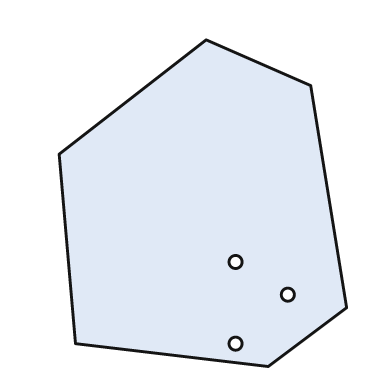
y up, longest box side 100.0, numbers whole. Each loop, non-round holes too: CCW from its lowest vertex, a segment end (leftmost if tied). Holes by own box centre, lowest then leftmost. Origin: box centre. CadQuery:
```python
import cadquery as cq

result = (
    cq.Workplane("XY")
    .moveTo(20.0, -50.0)
    .lineTo(44.0, -32.0)
    .lineTo(33.0, 36.0)
    .lineTo(1.0, 50.0)
    .lineTo(-44.0, 15.0)
    .lineTo(-39.0, -43.0)
    .close()
    .moveTo(10.0, -43.0)
    .circle(2.0)
    .moveTo(26.0, -28.0)
    .circle(2.0)
    .moveTo(10.0, -18.0)
    .circle(2.0)
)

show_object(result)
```